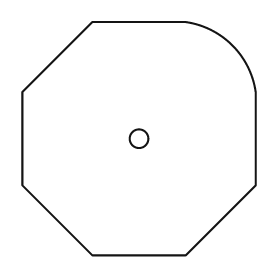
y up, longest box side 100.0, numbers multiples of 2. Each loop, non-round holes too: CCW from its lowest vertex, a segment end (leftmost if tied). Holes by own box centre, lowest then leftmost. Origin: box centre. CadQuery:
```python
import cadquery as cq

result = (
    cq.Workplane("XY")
    .moveTo(-20.0, -50.0)
    .lineTo(20.0, -50.0)
    .lineTo(50.0, -20.0)
    .lineTo(50.0, 20.0)
    .threePointArc((40.0, 40.0), (20.0, 50.0))
    .lineTo(-20.0, 50.0)
    .lineTo(-50.0, 20.0)
    .lineTo(-50.0, -20.0)
    .close()
    .moveTo(0.0, 0.0)
    .circle(4.0)
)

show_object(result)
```